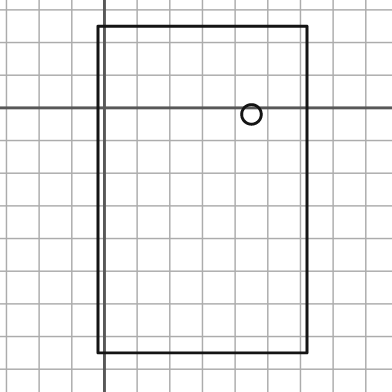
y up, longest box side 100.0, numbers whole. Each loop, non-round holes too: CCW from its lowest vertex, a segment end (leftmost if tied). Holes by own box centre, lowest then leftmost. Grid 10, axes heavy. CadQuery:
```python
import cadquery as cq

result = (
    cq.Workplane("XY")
    .moveTo(-2.0, -75.0)
    .lineTo(62.0, -75.0)
    .lineTo(62.0, 25.0)
    .lineTo(-2.0, 25.0)
    .close()
    .moveTo(45.0, -2.0)
    .circle(3.0)
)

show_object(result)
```